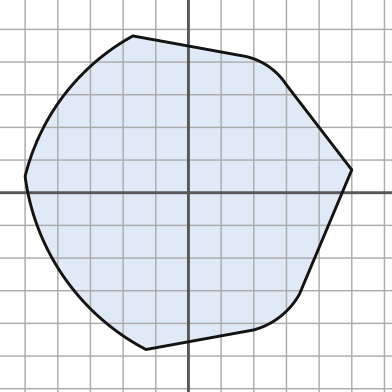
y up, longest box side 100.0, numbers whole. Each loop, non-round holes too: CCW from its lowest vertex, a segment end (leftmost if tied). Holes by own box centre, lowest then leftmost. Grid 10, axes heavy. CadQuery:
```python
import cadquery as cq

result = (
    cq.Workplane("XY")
    .moveTo(-13.0, -48.0)
    .lineTo(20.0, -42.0)
    .threePointArc((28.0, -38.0), (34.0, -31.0))
    .lineTo(50.0, 7.0)
    .lineTo(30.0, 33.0)
    .threePointArc((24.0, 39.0), (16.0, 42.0))
    .lineTo(-17.0, 48.0)
    .threePointArc((-38.0, 30.0), (-50.0, 5.0))
    .threePointArc((-38.0, -26.0), (-13.0, -48.0))
    .close()
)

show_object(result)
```